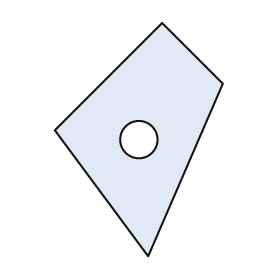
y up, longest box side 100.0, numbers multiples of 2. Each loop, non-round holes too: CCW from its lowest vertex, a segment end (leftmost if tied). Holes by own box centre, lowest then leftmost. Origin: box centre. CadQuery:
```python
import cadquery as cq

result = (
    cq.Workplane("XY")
    .moveTo(4.0, -50.0)
    .lineTo(36.0, 24.0)
    .lineTo(10.0, 50.0)
    .lineTo(-36.0, 4.0)
    .close()
    .moveTo(0.0, 0.0)
    .circle(8.0)
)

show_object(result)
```